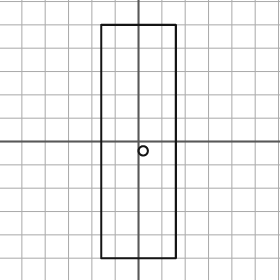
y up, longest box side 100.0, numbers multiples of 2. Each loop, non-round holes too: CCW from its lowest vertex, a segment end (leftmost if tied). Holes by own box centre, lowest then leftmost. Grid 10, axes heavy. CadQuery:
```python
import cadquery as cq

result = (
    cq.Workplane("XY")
    .moveTo(-16.0, -50.0)
    .lineTo(16.0, -50.0)
    .lineTo(16.0, 50.0)
    .lineTo(-16.0, 50.0)
    .close()
    .moveTo(2.0, -4.0)
    .circle(2.0)
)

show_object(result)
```